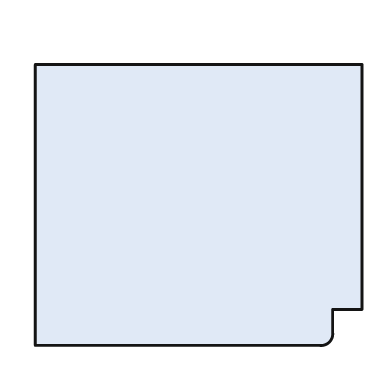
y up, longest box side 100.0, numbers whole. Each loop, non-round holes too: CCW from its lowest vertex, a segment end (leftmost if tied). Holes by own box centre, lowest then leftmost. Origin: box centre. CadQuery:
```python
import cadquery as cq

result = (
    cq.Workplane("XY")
    .moveTo(-50.0, -43.0)
    .lineTo(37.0, -43.0)
    .threePointArc((40.0, -42.0), (41.0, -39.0))
    .lineTo(41.0, -32.0)
    .lineTo(50.0, -32.0)
    .lineTo(50.0, 43.0)
    .lineTo(-50.0, 43.0)
    .close()
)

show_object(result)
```